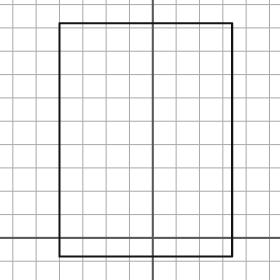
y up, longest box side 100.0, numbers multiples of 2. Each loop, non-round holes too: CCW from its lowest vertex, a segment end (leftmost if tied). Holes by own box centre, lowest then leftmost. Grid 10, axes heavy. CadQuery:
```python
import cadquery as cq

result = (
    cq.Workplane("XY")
    .moveTo(-40.0, -8.0)
    .lineTo(34.0, -8.0)
    .lineTo(34.0, 92.0)
    .lineTo(-40.0, 92.0)
    .close()
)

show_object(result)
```